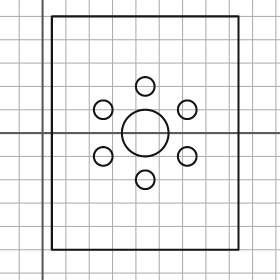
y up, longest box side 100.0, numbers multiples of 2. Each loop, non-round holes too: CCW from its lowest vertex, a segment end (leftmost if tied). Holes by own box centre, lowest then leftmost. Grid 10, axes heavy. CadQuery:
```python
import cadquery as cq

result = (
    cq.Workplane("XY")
    .moveTo(4.0, -50.0)
    .lineTo(84.0, -50.0)
    .lineTo(84.0, 50.0)
    .lineTo(4.0, 50.0)
    .close()
    .moveTo(44.0, -20.0)
    .circle(4.0)
    .moveTo(26.0, -10.0)
    .circle(4.0)
    .moveTo(62.0, -10.0)
    .circle(4.0)
    .moveTo(44.0, 0.0)
    .circle(10.0)
    .moveTo(26.0, 10.0)
    .circle(4.0)
    .moveTo(62.0, 10.0)
    .circle(4.0)
    .moveTo(44.0, 20.0)
    .circle(4.0)
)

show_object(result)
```